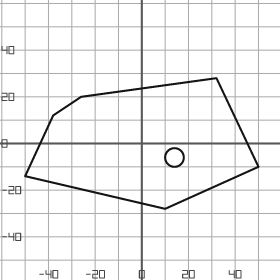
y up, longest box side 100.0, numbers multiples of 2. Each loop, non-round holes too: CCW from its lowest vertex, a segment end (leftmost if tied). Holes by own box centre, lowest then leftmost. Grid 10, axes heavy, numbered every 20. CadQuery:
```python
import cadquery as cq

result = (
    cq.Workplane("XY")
    .moveTo(10.0, -28.0)
    .lineTo(50.0, -10.0)
    .lineTo(32.0, 28.0)
    .lineTo(-26.0, 20.0)
    .lineTo(-38.0, 12.0)
    .lineTo(-50.0, -14.0)
    .close()
    .moveTo(14.0, -6.0)
    .circle(4.0)
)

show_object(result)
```